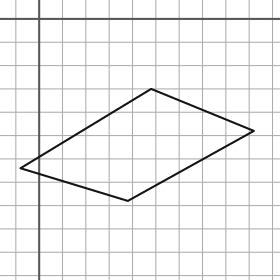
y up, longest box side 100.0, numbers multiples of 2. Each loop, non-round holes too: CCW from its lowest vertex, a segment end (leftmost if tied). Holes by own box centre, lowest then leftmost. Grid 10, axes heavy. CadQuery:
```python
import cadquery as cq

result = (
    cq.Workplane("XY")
    .moveTo(38.0, -78.0)
    .lineTo(92.0, -48.0)
    .lineTo(48.0, -30.0)
    .lineTo(-8.0, -64.0)
    .close()
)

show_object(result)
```